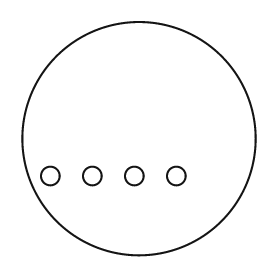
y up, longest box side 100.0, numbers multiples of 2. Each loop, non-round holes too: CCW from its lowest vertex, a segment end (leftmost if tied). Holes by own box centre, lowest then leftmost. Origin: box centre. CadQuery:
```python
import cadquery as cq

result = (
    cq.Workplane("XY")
    .moveTo(0.0, 0.0)
    .circle(50.0)
    .moveTo(-38.0, -16.0)
    .circle(4.0)
    .moveTo(-20.0, -16.0)
    .circle(4.0)
    .moveTo(-2.0, -16.0)
    .circle(4.0)
    .moveTo(16.0, -16.0)
    .circle(4.0)
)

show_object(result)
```